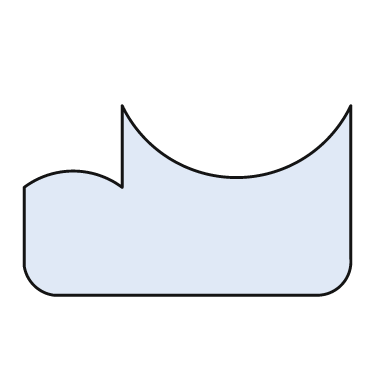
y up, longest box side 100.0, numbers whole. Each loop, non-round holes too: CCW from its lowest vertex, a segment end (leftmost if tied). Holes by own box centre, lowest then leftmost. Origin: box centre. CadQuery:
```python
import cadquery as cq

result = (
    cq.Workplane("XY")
    .moveTo(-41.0, -29.0)
    .lineTo(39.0, -29.0)
    .threePointArc((47.0, -26.0), (50.0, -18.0))
    .lineTo(50.0, 29.0)
    .threePointArc((15.0, 7.0), (-20.0, 29.0))
    .lineTo(-20.0, 4.0)
    .threePointArc((-35.0, 9.0), (-50.0, 4.0))
    .lineTo(-50.0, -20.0)
    .threePointArc((-47.0, -26.0), (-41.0, -29.0))
    .close()
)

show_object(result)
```